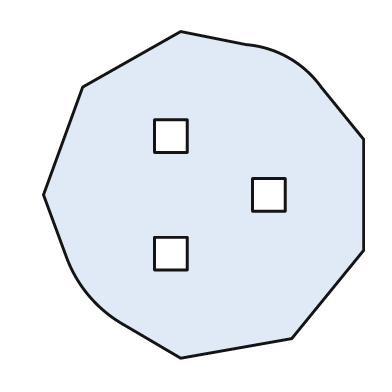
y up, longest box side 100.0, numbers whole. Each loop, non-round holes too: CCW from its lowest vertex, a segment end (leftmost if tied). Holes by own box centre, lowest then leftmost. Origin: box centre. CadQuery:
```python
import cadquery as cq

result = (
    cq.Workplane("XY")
    .moveTo(-7.0, -50.0)
    .lineTo(27.0, -44.0)
    .lineTo(49.0, -17.0)
    .lineTo(49.0, 17.0)
    .lineTo(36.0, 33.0)
    .threePointArc((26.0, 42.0), (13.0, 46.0))
    .lineTo(-7.0, 50.0)
    .lineTo(-37.0, 33.0)
    .lineTo(-49.0, 0.0)
    .lineTo(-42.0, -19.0)
    .threePointArc((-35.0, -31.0), (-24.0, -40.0))
    .close()
    .moveTo(-15.0, -23.0)
    .lineTo(-5.0, -23.0)
    .lineTo(-5.0, -13.0)
    .lineTo(-15.0, -13.0)
    .close()
    .moveTo(15.0, -5.0)
    .lineTo(25.0, -5.0)
    .lineTo(25.0, 5.0)
    .lineTo(15.0, 5.0)
    .close()
    .moveTo(-15.0, 13.0)
    .lineTo(-5.0, 13.0)
    .lineTo(-5.0, 23.0)
    .lineTo(-15.0, 23.0)
    .close()
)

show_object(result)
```